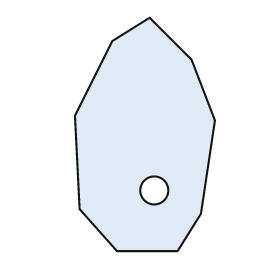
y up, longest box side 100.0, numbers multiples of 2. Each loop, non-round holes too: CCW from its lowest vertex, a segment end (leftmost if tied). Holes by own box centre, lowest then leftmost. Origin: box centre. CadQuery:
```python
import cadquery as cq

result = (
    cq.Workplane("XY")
    .moveTo(-12.0, -50.0)
    .lineTo(14.0, -50.0)
    .lineTo(24.0, -34.0)
    .lineTo(30.0, 6.0)
    .lineTo(20.0, 32.0)
    .lineTo(2.0, 50.0)
    .lineTo(-14.0, 40.0)
    .lineTo(-30.0, 8.0)
    .lineTo(-28.0, -32.0)
    .close()
    .moveTo(4.0, -24.0)
    .circle(6.0)
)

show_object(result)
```